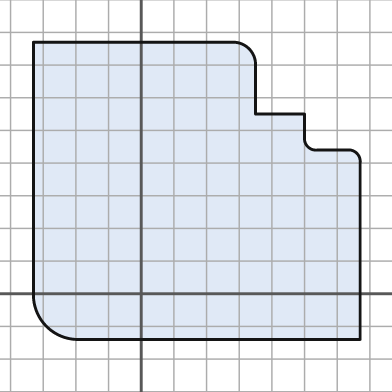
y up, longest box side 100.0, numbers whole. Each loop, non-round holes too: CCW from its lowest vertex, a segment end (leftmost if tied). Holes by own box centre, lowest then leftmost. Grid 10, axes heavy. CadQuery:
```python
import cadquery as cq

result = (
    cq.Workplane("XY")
    .moveTo(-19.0, -14.0)
    .lineTo(67.0, -14.0)
    .lineTo(67.0, 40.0)
    .threePointArc((66.0, 43.0), (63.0, 44.0))
    .lineTo(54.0, 44.0)
    .threePointArc((51.0, 45.0), (50.0, 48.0))
    .lineTo(50.0, 55.0)
    .lineTo(35.0, 55.0)
    .lineTo(35.0, 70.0)
    .threePointArc((33.0, 75.0), (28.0, 77.0))
    .lineTo(-33.0, 77.0)
    .lineTo(-33.0, 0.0)
    .threePointArc((-29.0, -10.0), (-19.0, -14.0))
    .close()
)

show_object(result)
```